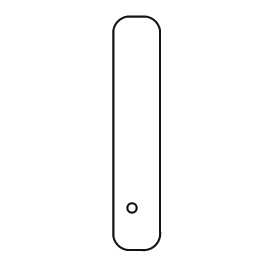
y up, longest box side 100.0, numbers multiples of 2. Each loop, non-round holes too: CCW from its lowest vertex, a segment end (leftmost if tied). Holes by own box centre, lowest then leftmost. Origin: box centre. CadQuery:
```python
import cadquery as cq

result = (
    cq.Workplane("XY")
    .moveTo(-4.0, -50.0)
    .lineTo(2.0, -50.0)
    .threePointArc((8.0, -48.0), (10.0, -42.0))
    .lineTo(10.0, 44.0)
    .threePointArc((8.0, 48.0), (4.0, 50.0))
    .lineTo(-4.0, 50.0)
    .threePointArc((-8.0, 48.0), (-10.0, 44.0))
    .lineTo(-10.0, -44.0)
    .threePointArc((-8.0, -48.0), (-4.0, -50.0))
    .close()
    .moveTo(-2.0, -32.0)
    .circle(2.0)
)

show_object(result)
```